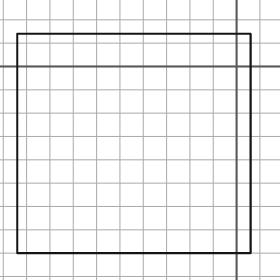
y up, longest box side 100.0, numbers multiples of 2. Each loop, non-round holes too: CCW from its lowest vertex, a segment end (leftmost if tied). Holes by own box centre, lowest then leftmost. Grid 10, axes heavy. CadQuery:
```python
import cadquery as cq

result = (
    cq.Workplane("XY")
    .moveTo(-94.0, -80.0)
    .lineTo(6.0, -80.0)
    .lineTo(6.0, 14.0)
    .lineTo(-94.0, 14.0)
    .close()
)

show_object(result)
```